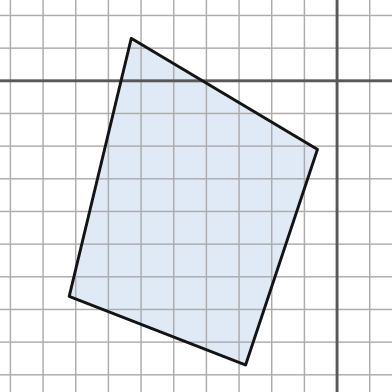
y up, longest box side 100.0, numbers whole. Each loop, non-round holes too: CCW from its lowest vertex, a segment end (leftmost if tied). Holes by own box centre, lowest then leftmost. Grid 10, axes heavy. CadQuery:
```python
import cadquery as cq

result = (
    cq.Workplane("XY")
    .moveTo(-28.0, -87.0)
    .lineTo(-6.0, -21.0)
    .lineTo(-63.0, 13.0)
    .lineTo(-82.0, -66.0)
    .close()
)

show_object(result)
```